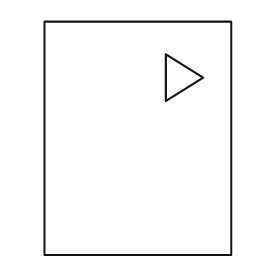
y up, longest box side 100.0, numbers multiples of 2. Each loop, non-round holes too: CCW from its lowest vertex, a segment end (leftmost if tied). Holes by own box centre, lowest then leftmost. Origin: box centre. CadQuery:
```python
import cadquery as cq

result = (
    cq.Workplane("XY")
    .moveTo(-40.0, -50.0)
    .lineTo(40.0, -50.0)
    .lineTo(40.0, 50.0)
    .lineTo(-40.0, 50.0)
    .close()
    .moveTo(12.0, 16.0)
    .lineTo(28.0, 26.0)
    .lineTo(12.0, 36.0)
    .close()
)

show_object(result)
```